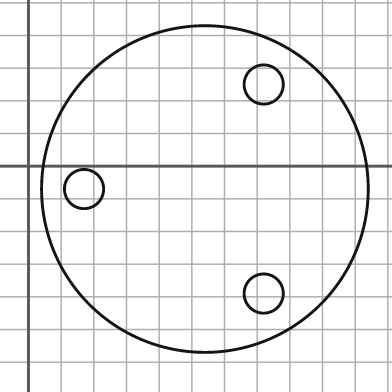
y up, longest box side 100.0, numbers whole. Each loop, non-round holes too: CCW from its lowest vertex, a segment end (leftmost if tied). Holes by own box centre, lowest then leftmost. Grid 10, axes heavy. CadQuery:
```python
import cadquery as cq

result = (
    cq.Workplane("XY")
    .moveTo(54.0, -7.0)
    .circle(50.0)
    .moveTo(72.0, -39.0)
    .circle(6.0)
    .moveTo(17.0, -7.0)
    .circle(6.0)
    .moveTo(72.0, 25.0)
    .circle(6.0)
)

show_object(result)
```